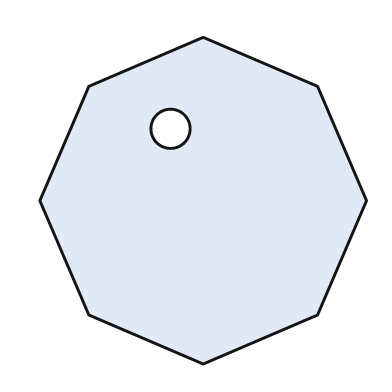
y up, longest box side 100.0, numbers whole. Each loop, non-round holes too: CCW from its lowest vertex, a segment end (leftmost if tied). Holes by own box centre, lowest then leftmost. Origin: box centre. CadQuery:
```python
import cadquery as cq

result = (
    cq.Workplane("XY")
    .moveTo(0.0, -50.0)
    .lineTo(35.0, -35.0)
    .lineTo(50.0, 0.0)
    .lineTo(35.0, 35.0)
    .lineTo(0.0, 50.0)
    .lineTo(-35.0, 35.0)
    .lineTo(-50.0, 0.0)
    .lineTo(-35.0, -35.0)
    .close()
    .moveTo(-10.0, 22.0)
    .circle(6.0)
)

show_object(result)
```